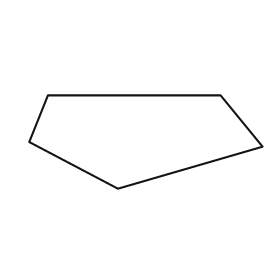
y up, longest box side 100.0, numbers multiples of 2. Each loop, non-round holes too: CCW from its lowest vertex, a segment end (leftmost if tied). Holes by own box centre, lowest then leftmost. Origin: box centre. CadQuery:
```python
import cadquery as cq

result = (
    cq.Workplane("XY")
    .moveTo(-12.0, -20.0)
    .lineTo(50.0, -2.0)
    .lineTo(32.0, 20.0)
    .lineTo(-42.0, 20.0)
    .lineTo(-50.0, 0.0)
    .close()
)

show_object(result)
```